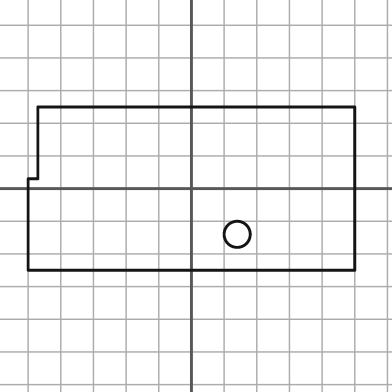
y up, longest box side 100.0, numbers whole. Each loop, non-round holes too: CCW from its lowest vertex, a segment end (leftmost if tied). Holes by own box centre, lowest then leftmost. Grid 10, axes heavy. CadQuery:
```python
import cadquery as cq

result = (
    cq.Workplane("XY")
    .moveTo(-50.0, -25.0)
    .lineTo(50.0, -25.0)
    .lineTo(50.0, 25.0)
    .lineTo(-47.0, 25.0)
    .lineTo(-47.0, 3.0)
    .lineTo(-50.0, 3.0)
    .close()
    .moveTo(14.0, -14.0)
    .circle(4.0)
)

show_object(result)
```